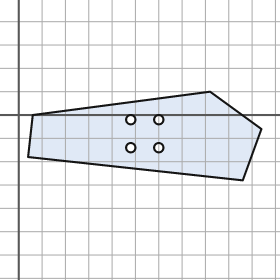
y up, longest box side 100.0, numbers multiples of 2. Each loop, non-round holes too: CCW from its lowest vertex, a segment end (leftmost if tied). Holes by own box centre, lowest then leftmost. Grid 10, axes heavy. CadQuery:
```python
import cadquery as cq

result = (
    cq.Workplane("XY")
    .moveTo(96.0, -28.0)
    .lineTo(104.0, -6.0)
    .lineTo(82.0, 10.0)
    .lineTo(6.0, 0.0)
    .lineTo(4.0, -18.0)
    .close()
    .moveTo(48.0, -14.0)
    .circle(2.0)
    .moveTo(60.0, -14.0)
    .circle(2.0)
    .moveTo(48.0, -2.0)
    .circle(2.0)
    .moveTo(60.0, -2.0)
    .circle(2.0)
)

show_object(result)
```